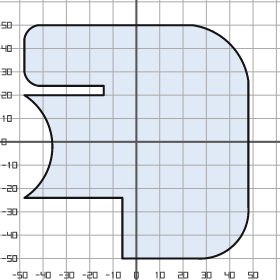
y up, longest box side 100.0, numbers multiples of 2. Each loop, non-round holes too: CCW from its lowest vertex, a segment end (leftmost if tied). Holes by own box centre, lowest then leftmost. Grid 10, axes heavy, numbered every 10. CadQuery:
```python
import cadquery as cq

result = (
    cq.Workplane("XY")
    .moveTo(-6.0, -50.0)
    .lineTo(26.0, -50.0)
    .threePointArc((42.0, -44.0), (48.0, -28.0))
    .lineTo(48.0, 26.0)
    .threePointArc((40.0, 42.0), (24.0, 50.0))
    .lineTo(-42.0, 50.0)
    .threePointArc((-46.0, 48.0), (-48.0, 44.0))
    .lineTo(-48.0, 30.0)
    .threePointArc((-46.0, 26.0), (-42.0, 24.0))
    .lineTo(-14.0, 24.0)
    .lineTo(-14.0, 20.0)
    .lineTo(-48.0, 20.0)
    .threePointArc((-36.0, -2.0), (-48.0, -24.0))
    .lineTo(-6.0, -24.0)
    .close()
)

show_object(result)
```